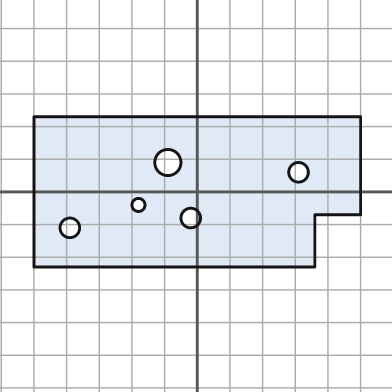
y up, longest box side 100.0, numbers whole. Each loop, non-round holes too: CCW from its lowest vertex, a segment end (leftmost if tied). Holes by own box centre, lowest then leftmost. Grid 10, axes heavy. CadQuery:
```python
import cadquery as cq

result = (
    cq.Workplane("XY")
    .moveTo(-50.0, -23.0)
    .lineTo(36.0, -23.0)
    .lineTo(36.0, -7.0)
    .lineTo(50.0, -7.0)
    .lineTo(50.0, 23.0)
    .lineTo(-50.0, 23.0)
    .close()
    .moveTo(-39.0, -11.0)
    .circle(3.0)
    .moveTo(-2.0, -8.0)
    .circle(3.0)
    .moveTo(-18.0, -4.0)
    .circle(2.0)
    .moveTo(31.0, 6.0)
    .circle(3.0)
    .moveTo(-9.0, 9.0)
    .circle(4.0)
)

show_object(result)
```